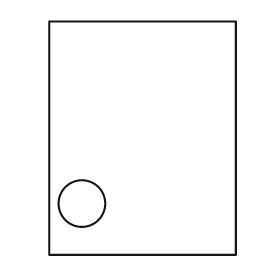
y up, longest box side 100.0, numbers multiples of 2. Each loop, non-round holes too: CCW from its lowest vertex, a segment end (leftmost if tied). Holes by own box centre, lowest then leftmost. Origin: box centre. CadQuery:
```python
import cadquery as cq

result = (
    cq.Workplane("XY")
    .moveTo(-40.0, -50.0)
    .lineTo(40.0, -50.0)
    .lineTo(40.0, 50.0)
    .lineTo(-40.0, 50.0)
    .close()
    .moveTo(-26.0, -28.0)
    .circle(10.0)
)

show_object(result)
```